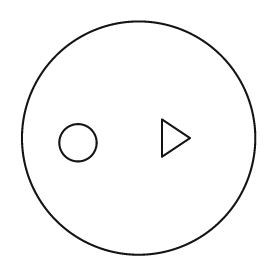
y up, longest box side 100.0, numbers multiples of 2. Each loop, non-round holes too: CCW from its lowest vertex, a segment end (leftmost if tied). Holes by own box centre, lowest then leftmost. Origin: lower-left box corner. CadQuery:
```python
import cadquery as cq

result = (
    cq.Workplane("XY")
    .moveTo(50.0, 50.0)
    .circle(50.0)
    .moveTo(24.0, 48.0)
    .circle(8.0)
    .moveTo(60.0, 42.0)
    .lineTo(72.0, 50.0)
    .lineTo(60.0, 58.0)
    .close()
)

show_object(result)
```